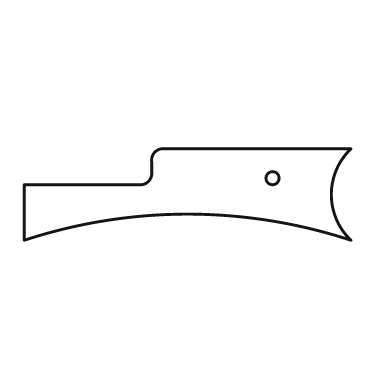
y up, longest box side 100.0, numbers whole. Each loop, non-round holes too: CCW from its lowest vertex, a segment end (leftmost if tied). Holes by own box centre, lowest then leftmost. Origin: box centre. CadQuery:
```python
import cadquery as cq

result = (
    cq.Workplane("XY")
    .moveTo(-50.0, -14.0)
    .threePointArc((0.0, -6.0), (50.0, -14.0))
    .threePointArc((44.0, 0.0), (50.0, 14.0))
    .lineTo(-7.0, 14.0)
    .threePointArc((-10.0, 13.0), (-11.0, 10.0))
    .lineTo(-11.0, 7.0)
    .threePointArc((-12.0, 4.0), (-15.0, 3.0))
    .lineTo(-50.0, 3.0)
    .close()
    .moveTo(26.0, 5.0)
    .circle(2.0)
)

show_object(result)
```